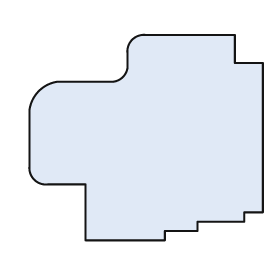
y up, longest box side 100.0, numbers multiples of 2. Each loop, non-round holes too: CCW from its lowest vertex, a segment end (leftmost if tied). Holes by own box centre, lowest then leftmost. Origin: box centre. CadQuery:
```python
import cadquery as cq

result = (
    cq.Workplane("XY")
    .moveTo(-26.0, -44.0)
    .lineTo(8.0, -44.0)
    .lineTo(8.0, -40.0)
    .lineTo(22.0, -40.0)
    .lineTo(22.0, -36.0)
    .lineTo(42.0, -36.0)
    .lineTo(42.0, -32.0)
    .lineTo(50.0, -32.0)
    .lineTo(50.0, 32.0)
    .lineTo(38.0, 32.0)
    .lineTo(38.0, 44.0)
    .lineTo(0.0, 44.0)
    .threePointArc((-6.0, 42.0), (-8.0, 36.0))
    .lineTo(-8.0, 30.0)
    .threePointArc((-10.0, 26.0), (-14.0, 24.0))
    .lineTo(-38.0, 24.0)
    .threePointArc((-46.0, 20.0), (-50.0, 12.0))
    .lineTo(-50.0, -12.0)
    .threePointArc((-48.0, -18.0), (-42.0, -20.0))
    .lineTo(-26.0, -20.0)
    .close()
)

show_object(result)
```